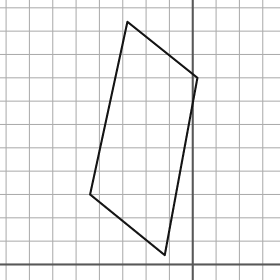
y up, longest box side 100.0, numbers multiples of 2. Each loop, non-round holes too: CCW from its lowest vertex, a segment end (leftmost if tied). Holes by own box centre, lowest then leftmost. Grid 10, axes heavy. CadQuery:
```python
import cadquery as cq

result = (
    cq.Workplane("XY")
    .moveTo(-12.0, 4.0)
    .lineTo(2.0, 80.0)
    .lineTo(-28.0, 104.0)
    .lineTo(-44.0, 30.0)
    .close()
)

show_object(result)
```